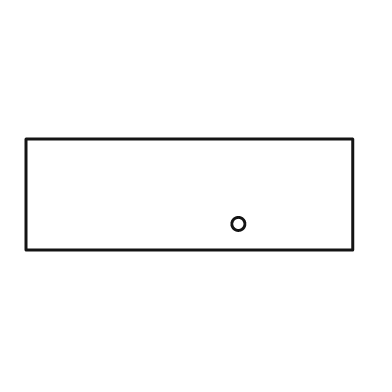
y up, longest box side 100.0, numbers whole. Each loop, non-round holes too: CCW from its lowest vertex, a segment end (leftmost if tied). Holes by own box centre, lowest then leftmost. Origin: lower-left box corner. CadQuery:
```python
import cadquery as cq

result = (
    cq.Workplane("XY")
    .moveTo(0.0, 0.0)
    .lineTo(100.0, 0.0)
    .lineTo(100.0, 34.0)
    .lineTo(0.0, 34.0)
    .close()
    .moveTo(65.0, 8.0)
    .circle(2.0)
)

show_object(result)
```